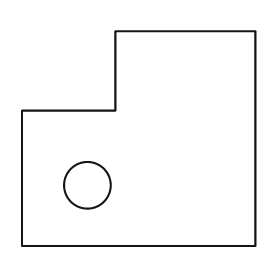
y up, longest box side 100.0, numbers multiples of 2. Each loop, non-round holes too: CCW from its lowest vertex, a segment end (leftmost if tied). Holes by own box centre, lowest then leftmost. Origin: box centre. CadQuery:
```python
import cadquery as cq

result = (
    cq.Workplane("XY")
    .moveTo(-50.0, -46.0)
    .lineTo(50.0, -46.0)
    .lineTo(50.0, 46.0)
    .lineTo(-10.0, 46.0)
    .lineTo(-10.0, 12.0)
    .lineTo(-50.0, 12.0)
    .close()
    .moveTo(-22.0, -20.0)
    .circle(10.0)
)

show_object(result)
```